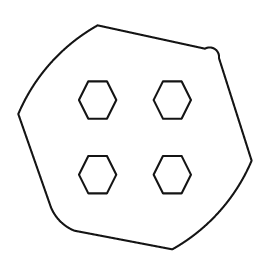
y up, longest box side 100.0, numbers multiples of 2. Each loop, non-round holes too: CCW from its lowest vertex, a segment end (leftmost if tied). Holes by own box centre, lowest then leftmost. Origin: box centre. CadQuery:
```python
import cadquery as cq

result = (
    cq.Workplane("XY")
    .moveTo(16.0, -48.0)
    .threePointArc((36.0, -32.0), (50.0, -10.0))
    .lineTo(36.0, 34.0)
    .threePointArc((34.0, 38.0), (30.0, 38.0))
    .lineTo(-16.0, 48.0)
    .threePointArc((-36.0, 32.0), (-50.0, 10.0))
    .lineTo(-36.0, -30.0)
    .threePointArc((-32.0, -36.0), (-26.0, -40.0))
    .close()
    .moveTo(-20.0, -24.0)
    .lineTo(-12.0, -24.0)
    .lineTo(-8.0, -16.0)
    .lineTo(-12.0, -8.0)
    .lineTo(-20.0, -8.0)
    .lineTo(-24.0, -16.0)
    .close()
    .moveTo(12.0, -24.0)
    .lineTo(20.0, -24.0)
    .lineTo(24.0, -16.0)
    .lineTo(20.0, -8.0)
    .lineTo(12.0, -8.0)
    .lineTo(8.0, -16.0)
    .close()
    .moveTo(-20.0, 8.0)
    .lineTo(-12.0, 8.0)
    .lineTo(-8.0, 16.0)
    .lineTo(-12.0, 24.0)
    .lineTo(-20.0, 24.0)
    .lineTo(-24.0, 16.0)
    .close()
    .moveTo(12.0, 8.0)
    .lineTo(20.0, 8.0)
    .lineTo(24.0, 16.0)
    .lineTo(20.0, 24.0)
    .lineTo(12.0, 24.0)
    .lineTo(8.0, 16.0)
    .close()
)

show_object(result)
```